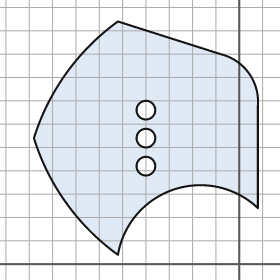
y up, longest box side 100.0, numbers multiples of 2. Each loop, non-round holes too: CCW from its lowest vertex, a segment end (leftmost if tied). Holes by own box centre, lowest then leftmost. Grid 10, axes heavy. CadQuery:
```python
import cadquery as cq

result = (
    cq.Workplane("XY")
    .moveTo(-52.0, 4.0)
    .threePointArc((-28.0, 32.0), (8.0, 24.0))
    .lineTo(8.0, 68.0)
    .threePointArc((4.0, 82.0), (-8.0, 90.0))
    .lineTo(-52.0, 104.0)
    .threePointArc((-74.0, 82.0), (-88.0, 54.0))
    .threePointArc((-74.0, 26.0), (-52.0, 4.0))
    .close()
    .moveTo(-40.0, 42.0)
    .circle(4.0)
    .moveTo(-40.0, 54.0)
    .circle(4.0)
    .moveTo(-40.0, 66.0)
    .circle(4.0)
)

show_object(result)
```